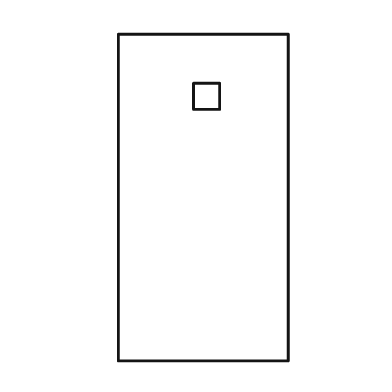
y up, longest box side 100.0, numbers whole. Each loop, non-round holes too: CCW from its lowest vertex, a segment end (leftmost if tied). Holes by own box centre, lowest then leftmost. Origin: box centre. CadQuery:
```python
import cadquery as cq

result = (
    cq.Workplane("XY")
    .moveTo(-26.0, -50.0)
    .lineTo(26.0, -50.0)
    .lineTo(26.0, 50.0)
    .lineTo(-26.0, 50.0)
    .close()
    .moveTo(-3.0, 27.0)
    .lineTo(5.0, 27.0)
    .lineTo(5.0, 35.0)
    .lineTo(-3.0, 35.0)
    .close()
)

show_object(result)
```